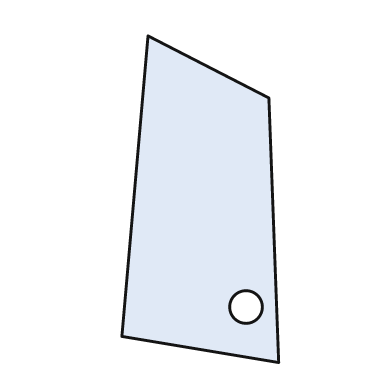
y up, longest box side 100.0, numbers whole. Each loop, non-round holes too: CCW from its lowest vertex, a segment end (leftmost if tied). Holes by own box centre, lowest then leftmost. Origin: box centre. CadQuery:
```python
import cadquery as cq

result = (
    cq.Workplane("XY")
    .moveTo(24.0, -50.0)
    .lineTo(21.0, 31.0)
    .lineTo(-16.0, 50.0)
    .lineTo(-24.0, -42.0)
    .close()
    .moveTo(14.0, -33.0)
    .circle(5.0)
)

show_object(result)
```